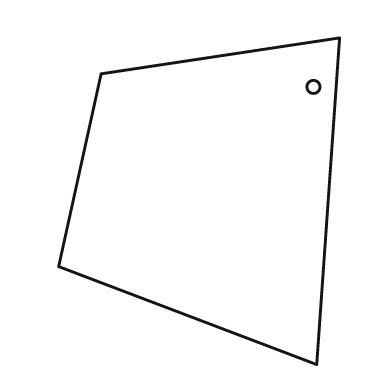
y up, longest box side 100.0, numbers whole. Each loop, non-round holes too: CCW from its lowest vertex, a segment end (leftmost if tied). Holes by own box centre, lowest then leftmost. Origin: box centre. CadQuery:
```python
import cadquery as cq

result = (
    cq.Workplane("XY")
    .moveTo(36.0, -50.0)
    .lineTo(43.0, 50.0)
    .lineTo(-30.0, 39.0)
    .lineTo(-43.0, -20.0)
    .close()
    .moveTo(35.0, 35.0)
    .circle(2.0)
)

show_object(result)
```